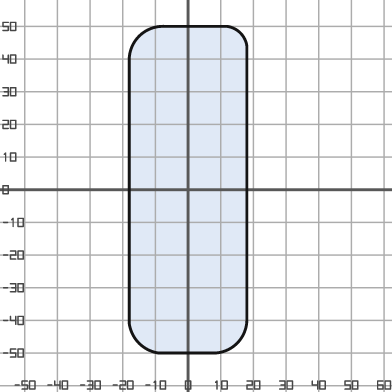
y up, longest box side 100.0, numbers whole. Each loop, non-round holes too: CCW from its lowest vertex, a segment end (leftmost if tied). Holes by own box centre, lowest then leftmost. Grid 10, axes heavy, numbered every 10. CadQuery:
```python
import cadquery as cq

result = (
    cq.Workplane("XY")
    .moveTo(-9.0, -50.0)
    .lineTo(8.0, -50.0)
    .threePointArc((15.0, -47.0), (18.0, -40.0))
    .lineTo(18.0, 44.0)
    .threePointArc((16.0, 48.0), (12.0, 50.0))
    .lineTo(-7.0, 50.0)
    .threePointArc((-15.0, 47.0), (-18.0, 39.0))
    .lineTo(-18.0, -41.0)
    .threePointArc((-15.0, -47.0), (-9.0, -50.0))
    .close()
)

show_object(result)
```